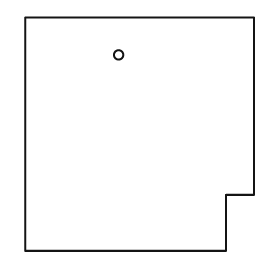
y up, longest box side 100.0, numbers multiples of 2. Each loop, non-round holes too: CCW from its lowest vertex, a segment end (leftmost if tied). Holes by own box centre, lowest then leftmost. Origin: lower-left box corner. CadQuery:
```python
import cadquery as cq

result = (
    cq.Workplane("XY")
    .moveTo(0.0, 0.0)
    .lineTo(86.0, 0.0)
    .lineTo(86.0, 24.0)
    .lineTo(98.0, 24.0)
    .lineTo(98.0, 100.0)
    .lineTo(0.0, 100.0)
    .close()
    .moveTo(40.0, 84.0)
    .circle(2.0)
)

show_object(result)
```